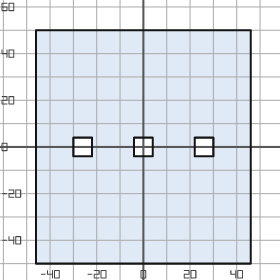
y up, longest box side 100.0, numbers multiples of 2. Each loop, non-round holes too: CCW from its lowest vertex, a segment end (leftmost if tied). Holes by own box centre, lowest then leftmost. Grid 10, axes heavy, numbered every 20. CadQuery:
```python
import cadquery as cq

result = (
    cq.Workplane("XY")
    .moveTo(-46.0, -50.0)
    .lineTo(46.0, -50.0)
    .lineTo(46.0, 50.0)
    .lineTo(-46.0, 50.0)
    .close()
    .moveTo(-30.0, -4.0)
    .lineTo(-22.0, -4.0)
    .lineTo(-22.0, 4.0)
    .lineTo(-30.0, 4.0)
    .close()
    .moveTo(-4.0, -4.0)
    .lineTo(4.0, -4.0)
    .lineTo(4.0, 4.0)
    .lineTo(-4.0, 4.0)
    .close()
    .moveTo(22.0, -4.0)
    .lineTo(30.0, -4.0)
    .lineTo(30.0, 4.0)
    .lineTo(22.0, 4.0)
    .close()
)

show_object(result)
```